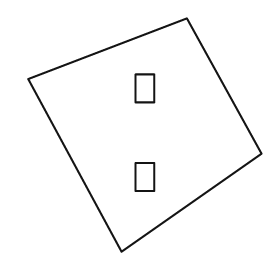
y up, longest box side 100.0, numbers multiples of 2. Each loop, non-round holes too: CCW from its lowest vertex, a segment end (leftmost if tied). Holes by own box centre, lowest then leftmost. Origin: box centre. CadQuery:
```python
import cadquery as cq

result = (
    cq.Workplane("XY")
    .moveTo(-10.0, -50.0)
    .lineTo(50.0, -8.0)
    .lineTo(18.0, 50.0)
    .lineTo(-50.0, 24.0)
    .close()
    .moveTo(-4.0, -24.0)
    .lineTo(4.0, -24.0)
    .lineTo(4.0, -12.0)
    .lineTo(-4.0, -12.0)
    .close()
    .moveTo(-4.0, 14.0)
    .lineTo(4.0, 14.0)
    .lineTo(4.0, 26.0)
    .lineTo(-4.0, 26.0)
    .close()
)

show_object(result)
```